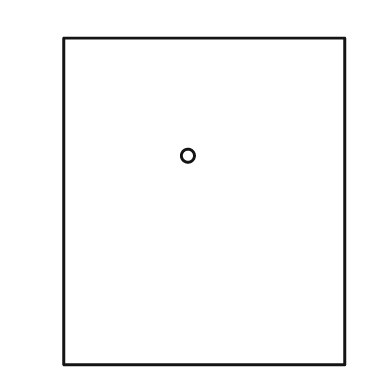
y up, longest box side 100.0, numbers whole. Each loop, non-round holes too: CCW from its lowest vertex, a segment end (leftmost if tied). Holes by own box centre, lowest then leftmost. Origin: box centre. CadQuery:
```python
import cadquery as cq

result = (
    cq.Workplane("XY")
    .moveTo(-43.0, -50.0)
    .lineTo(43.0, -50.0)
    .lineTo(43.0, 50.0)
    .lineTo(-43.0, 50.0)
    .close()
    .moveTo(-5.0, 14.0)
    .circle(2.0)
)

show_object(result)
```